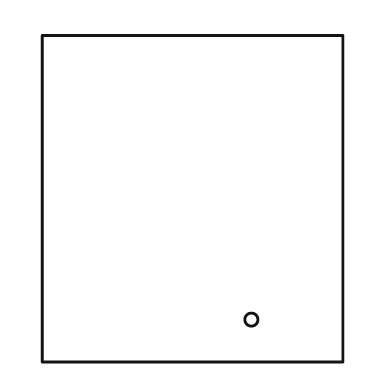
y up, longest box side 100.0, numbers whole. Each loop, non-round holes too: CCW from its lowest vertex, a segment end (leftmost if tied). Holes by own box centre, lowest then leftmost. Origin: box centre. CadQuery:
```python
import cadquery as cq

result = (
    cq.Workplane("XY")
    .moveTo(-46.0, -50.0)
    .lineTo(46.0, -50.0)
    .lineTo(46.0, 50.0)
    .lineTo(-46.0, 50.0)
    .close()
    .moveTo(18.0, -37.0)
    .circle(2.0)
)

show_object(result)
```